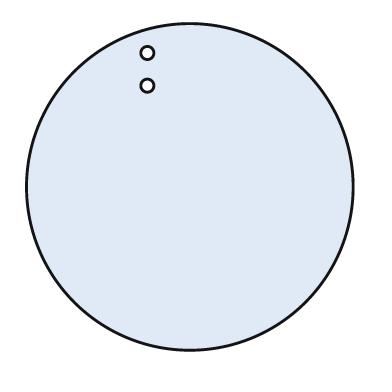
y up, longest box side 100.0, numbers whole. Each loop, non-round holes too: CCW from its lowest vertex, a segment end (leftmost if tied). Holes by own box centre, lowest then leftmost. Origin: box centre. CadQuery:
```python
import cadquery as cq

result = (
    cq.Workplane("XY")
    .moveTo(0.0, 0.0)
    .circle(50.0)
    .moveTo(-13.0, 31.0)
    .circle(2.0)
    .moveTo(-13.0, 41.0)
    .circle(2.0)
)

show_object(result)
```